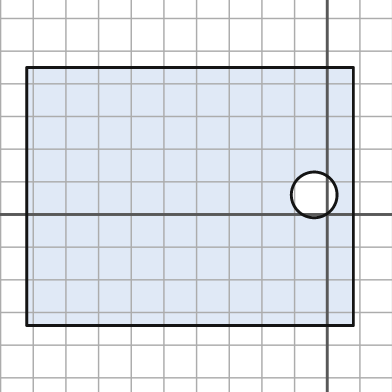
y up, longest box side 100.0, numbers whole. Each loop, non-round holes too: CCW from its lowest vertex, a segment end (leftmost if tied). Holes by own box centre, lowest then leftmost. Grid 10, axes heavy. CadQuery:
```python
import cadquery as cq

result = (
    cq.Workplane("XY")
    .moveTo(-92.0, -34.0)
    .lineTo(8.0, -34.0)
    .lineTo(8.0, 45.0)
    .lineTo(-92.0, 45.0)
    .close()
    .moveTo(-4.0, 6.0)
    .circle(7.0)
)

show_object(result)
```